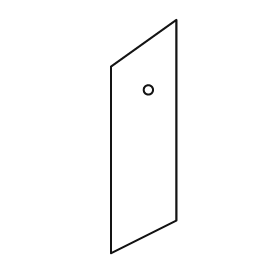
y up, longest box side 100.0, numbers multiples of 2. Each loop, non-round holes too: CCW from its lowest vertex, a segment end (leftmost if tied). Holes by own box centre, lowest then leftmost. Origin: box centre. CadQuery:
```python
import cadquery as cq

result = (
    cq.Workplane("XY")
    .moveTo(-14.0, -50.0)
    .lineTo(14.0, -36.0)
    .lineTo(14.0, 50.0)
    .lineTo(-14.0, 30.0)
    .close()
    .moveTo(2.0, 20.0)
    .circle(2.0)
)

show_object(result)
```